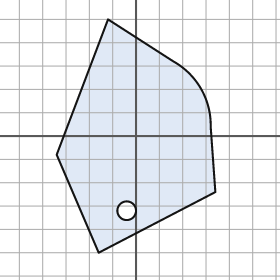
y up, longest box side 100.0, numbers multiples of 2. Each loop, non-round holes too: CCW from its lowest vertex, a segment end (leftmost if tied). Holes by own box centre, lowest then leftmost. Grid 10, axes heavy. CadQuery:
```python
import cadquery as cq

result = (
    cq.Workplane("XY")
    .moveTo(-16.0, -50.0)
    .lineTo(34.0, -24.0)
    .lineTo(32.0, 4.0)
    .threePointArc((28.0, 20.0), (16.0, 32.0))
    .lineTo(-12.0, 50.0)
    .lineTo(-34.0, -8.0)
    .close()
    .moveTo(-4.0, -32.0)
    .circle(4.0)
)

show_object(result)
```